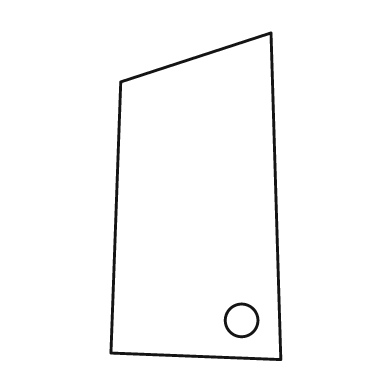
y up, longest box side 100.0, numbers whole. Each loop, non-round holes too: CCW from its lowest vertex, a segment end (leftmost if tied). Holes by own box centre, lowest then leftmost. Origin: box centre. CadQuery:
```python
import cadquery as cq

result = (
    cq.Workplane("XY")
    .moveTo(26.0, -50.0)
    .lineTo(23.0, 50.0)
    .lineTo(-23.0, 35.0)
    .lineTo(-26.0, -48.0)
    .close()
    .moveTo(14.0, -38.0)
    .circle(5.0)
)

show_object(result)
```